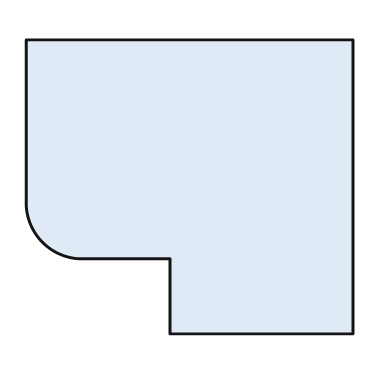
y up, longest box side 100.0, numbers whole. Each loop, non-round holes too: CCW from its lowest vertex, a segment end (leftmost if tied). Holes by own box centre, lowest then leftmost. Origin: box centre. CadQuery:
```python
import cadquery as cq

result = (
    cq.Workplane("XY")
    .moveTo(-6.0, -45.0)
    .lineTo(50.0, -45.0)
    .lineTo(50.0, 45.0)
    .lineTo(-50.0, 45.0)
    .lineTo(-50.0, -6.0)
    .threePointArc((-45.0, -17.0), (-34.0, -22.0))
    .lineTo(-6.0, -22.0)
    .close()
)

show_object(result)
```